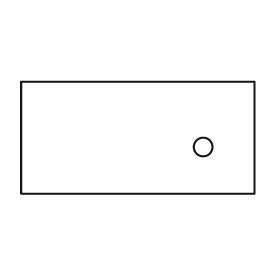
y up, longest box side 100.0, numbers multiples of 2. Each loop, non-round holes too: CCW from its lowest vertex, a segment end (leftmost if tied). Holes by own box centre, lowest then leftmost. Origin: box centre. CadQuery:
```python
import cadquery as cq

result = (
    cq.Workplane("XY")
    .moveTo(-50.0, -24.0)
    .lineTo(50.0, -24.0)
    .lineTo(50.0, 24.0)
    .lineTo(-50.0, 24.0)
    .close()
    .moveTo(28.0, -4.0)
    .circle(4.0)
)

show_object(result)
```